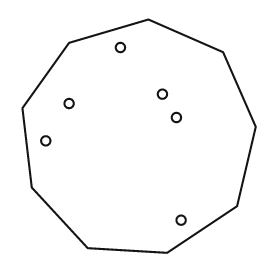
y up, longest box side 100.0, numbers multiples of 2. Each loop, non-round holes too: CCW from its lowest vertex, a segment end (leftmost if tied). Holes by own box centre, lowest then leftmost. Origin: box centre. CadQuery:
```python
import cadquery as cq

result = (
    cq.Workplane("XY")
    .moveTo(12.0, -50.0)
    .lineTo(42.0, -30.0)
    .lineTo(50.0, 4.0)
    .lineTo(36.0, 36.0)
    .lineTo(4.0, 50.0)
    .lineTo(-30.0, 40.0)
    .lineTo(-50.0, 12.0)
    .lineTo(-46.0, -22.0)
    .lineTo(-22.0, -48.0)
    .close()
    .moveTo(18.0, -36.0)
    .circle(2.0)
    .moveTo(-40.0, -2.0)
    .circle(2.0)
    .moveTo(16.0, 8.0)
    .circle(2.0)
    .moveTo(-30.0, 14.0)
    .circle(2.0)
    .moveTo(10.0, 18.0)
    .circle(2.0)
    .moveTo(-8.0, 38.0)
    .circle(2.0)
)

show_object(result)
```